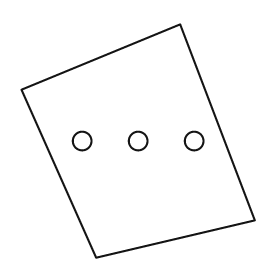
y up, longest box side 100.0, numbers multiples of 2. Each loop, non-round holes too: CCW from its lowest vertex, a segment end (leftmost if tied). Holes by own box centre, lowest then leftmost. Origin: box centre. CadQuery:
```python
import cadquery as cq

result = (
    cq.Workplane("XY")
    .moveTo(-18.0, -50.0)
    .lineTo(50.0, -34.0)
    .lineTo(18.0, 50.0)
    .lineTo(-50.0, 22.0)
    .close()
    .moveTo(-24.0, 0.0)
    .circle(4.0)
    .moveTo(0.0, 0.0)
    .circle(4.0)
    .moveTo(24.0, 0.0)
    .circle(4.0)
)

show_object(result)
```